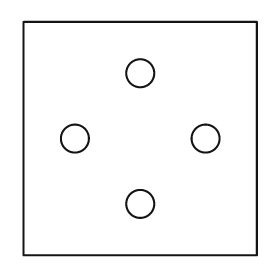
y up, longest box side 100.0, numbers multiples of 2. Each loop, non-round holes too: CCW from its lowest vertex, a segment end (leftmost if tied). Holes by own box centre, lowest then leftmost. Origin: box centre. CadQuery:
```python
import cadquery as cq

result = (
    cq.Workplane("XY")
    .moveTo(-50.0, -50.0)
    .lineTo(50.0, -50.0)
    .lineTo(50.0, 50.0)
    .lineTo(-50.0, 50.0)
    .close()
    .moveTo(0.0, -28.0)
    .circle(6.0)
    .moveTo(-28.0, 0.0)
    .circle(6.0)
    .moveTo(28.0, 0.0)
    .circle(6.0)
    .moveTo(0.0, 28.0)
    .circle(6.0)
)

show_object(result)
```